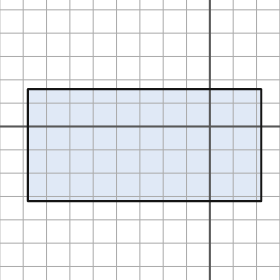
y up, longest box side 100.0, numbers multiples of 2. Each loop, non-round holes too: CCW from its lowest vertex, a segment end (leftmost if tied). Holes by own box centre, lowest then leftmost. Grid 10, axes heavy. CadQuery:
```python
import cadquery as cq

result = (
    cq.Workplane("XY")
    .moveTo(-78.0, -32.0)
    .lineTo(22.0, -32.0)
    .lineTo(22.0, 16.0)
    .lineTo(-78.0, 16.0)
    .close()
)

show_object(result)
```